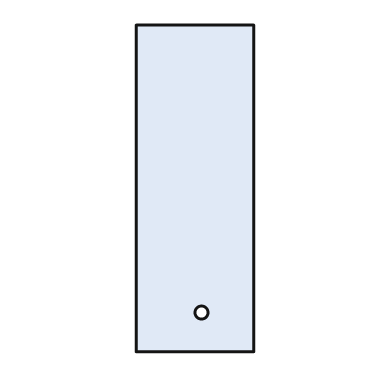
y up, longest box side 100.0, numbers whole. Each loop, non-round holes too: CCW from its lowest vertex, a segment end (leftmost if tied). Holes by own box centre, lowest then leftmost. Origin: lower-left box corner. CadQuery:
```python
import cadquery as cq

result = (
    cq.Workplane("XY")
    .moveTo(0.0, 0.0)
    .lineTo(36.0, 0.0)
    .lineTo(36.0, 100.0)
    .lineTo(0.0, 100.0)
    .close()
    .moveTo(20.0, 12.0)
    .circle(2.0)
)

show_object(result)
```